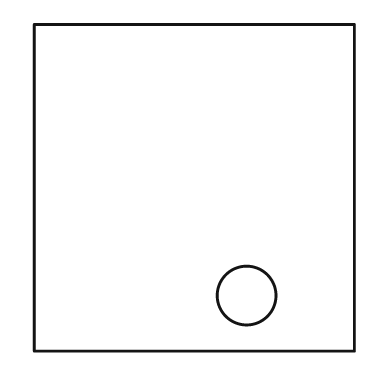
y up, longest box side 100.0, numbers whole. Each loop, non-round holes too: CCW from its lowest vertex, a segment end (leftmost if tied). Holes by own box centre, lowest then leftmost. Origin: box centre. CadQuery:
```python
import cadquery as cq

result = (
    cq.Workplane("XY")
    .moveTo(-49.0, -50.0)
    .lineTo(49.0, -50.0)
    .lineTo(49.0, 50.0)
    .lineTo(-49.0, 50.0)
    .close()
    .moveTo(16.0, -33.0)
    .circle(9.0)
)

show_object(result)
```